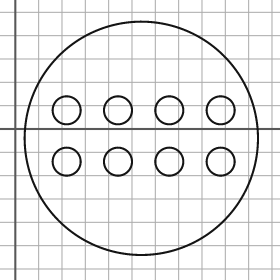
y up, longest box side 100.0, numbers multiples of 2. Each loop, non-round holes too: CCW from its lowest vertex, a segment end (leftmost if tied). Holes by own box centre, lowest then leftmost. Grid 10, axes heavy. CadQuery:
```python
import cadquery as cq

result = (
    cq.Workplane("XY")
    .moveTo(54.0, -4.0)
    .circle(50.0)
    .moveTo(22.0, -14.0)
    .circle(6.0)
    .moveTo(44.0, -14.0)
    .circle(6.0)
    .moveTo(66.0, -14.0)
    .circle(6.0)
    .moveTo(88.0, -14.0)
    .circle(6.0)
    .moveTo(22.0, 8.0)
    .circle(6.0)
    .moveTo(44.0, 8.0)
    .circle(6.0)
    .moveTo(66.0, 8.0)
    .circle(6.0)
    .moveTo(88.0, 8.0)
    .circle(6.0)
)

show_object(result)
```